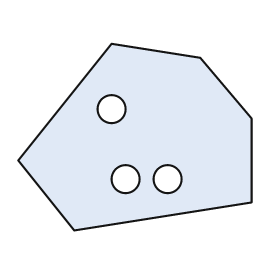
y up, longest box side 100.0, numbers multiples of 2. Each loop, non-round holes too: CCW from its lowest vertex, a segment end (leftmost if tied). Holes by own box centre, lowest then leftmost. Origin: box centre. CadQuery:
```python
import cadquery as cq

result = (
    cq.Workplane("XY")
    .moveTo(-26.0, -40.0)
    .lineTo(50.0, -28.0)
    .lineTo(50.0, 8.0)
    .lineTo(28.0, 34.0)
    .lineTo(-10.0, 40.0)
    .lineTo(-50.0, -10.0)
    .close()
    .moveTo(-4.0, -18.0)
    .circle(6.0)
    .moveTo(14.0, -18.0)
    .circle(6.0)
    .moveTo(-10.0, 12.0)
    .circle(6.0)
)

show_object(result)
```